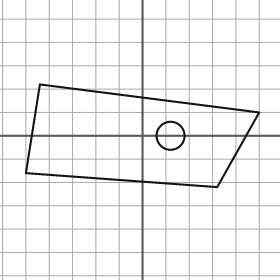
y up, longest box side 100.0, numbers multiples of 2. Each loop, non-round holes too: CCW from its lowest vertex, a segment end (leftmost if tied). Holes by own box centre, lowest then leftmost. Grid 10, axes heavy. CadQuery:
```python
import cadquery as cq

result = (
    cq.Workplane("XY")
    .moveTo(32.0, -22.0)
    .lineTo(50.0, 10.0)
    .lineTo(-44.0, 22.0)
    .lineTo(-50.0, -16.0)
    .close()
    .moveTo(12.0, 0.0)
    .circle(6.0)
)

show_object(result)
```